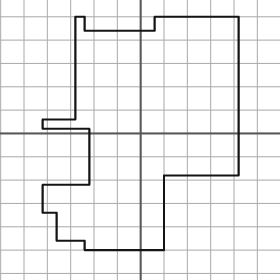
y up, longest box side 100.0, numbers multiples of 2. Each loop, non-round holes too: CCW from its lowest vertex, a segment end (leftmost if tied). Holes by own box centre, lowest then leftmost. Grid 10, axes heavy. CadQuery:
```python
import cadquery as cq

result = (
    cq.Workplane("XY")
    .moveTo(-24.0, -50.0)
    .lineTo(10.0, -50.0)
    .lineTo(10.0, -18.0)
    .lineTo(42.0, -18.0)
    .lineTo(42.0, 50.0)
    .lineTo(6.0, 50.0)
    .lineTo(6.0, 44.0)
    .lineTo(-24.0, 44.0)
    .lineTo(-24.0, 50.0)
    .lineTo(-28.0, 50.0)
    .lineTo(-28.0, 6.0)
    .lineTo(-42.0, 6.0)
    .lineTo(-42.0, 2.0)
    .lineTo(-22.0, 2.0)
    .lineTo(-22.0, -22.0)
    .lineTo(-42.0, -22.0)
    .lineTo(-42.0, -34.0)
    .lineTo(-36.0, -34.0)
    .lineTo(-36.0, -46.0)
    .lineTo(-24.0, -46.0)
    .close()
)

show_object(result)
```